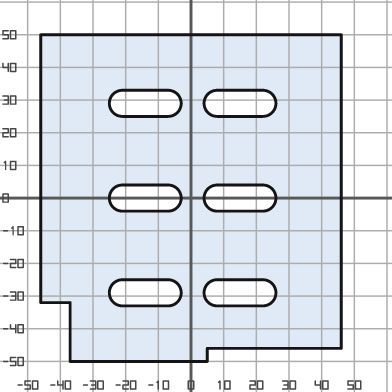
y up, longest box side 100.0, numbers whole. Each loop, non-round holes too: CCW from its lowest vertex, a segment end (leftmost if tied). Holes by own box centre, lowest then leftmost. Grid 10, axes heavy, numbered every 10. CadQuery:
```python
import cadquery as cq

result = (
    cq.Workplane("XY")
    .moveTo(-37.0, -50.0)
    .lineTo(5.0, -50.0)
    .lineTo(5.0, -46.0)
    .lineTo(46.0, -46.0)
    .lineTo(46.0, 50.0)
    .lineTo(-46.0, 50.0)
    .lineTo(-46.0, -32.0)
    .lineTo(-37.0, -32.0)
    .close()
    .moveTo(-21.0, -33.0)
    .lineTo(-7.0, -33.0)
    .threePointArc((-3.0, -29.0), (-7.0, -25.0))
    .lineTo(-21.0, -25.0)
    .threePointArc((-25.0, -29.0), (-21.0, -33.0))
    .close()
    .moveTo(8.0, -33.0)
    .lineTo(22.0, -33.0)
    .threePointArc((26.0, -29.0), (22.0, -25.0))
    .lineTo(8.0, -25.0)
    .threePointArc((4.0, -29.0), (8.0, -33.0))
    .close()
    .moveTo(-21.0, -4.0)
    .lineTo(-7.0, -4.0)
    .threePointArc((-3.0, 0.0), (-7.0, 4.0))
    .lineTo(-21.0, 4.0)
    .threePointArc((-25.0, 0.0), (-21.0, -4.0))
    .close()
    .moveTo(8.0, -4.0)
    .lineTo(22.0, -4.0)
    .threePointArc((26.0, 0.0), (22.0, 4.0))
    .lineTo(8.0, 4.0)
    .threePointArc((4.0, 0.0), (8.0, -4.0))
    .close()
    .moveTo(-21.0, 25.0)
    .lineTo(-7.0, 25.0)
    .threePointArc((-3.0, 29.0), (-7.0, 33.0))
    .lineTo(-21.0, 33.0)
    .threePointArc((-25.0, 29.0), (-21.0, 25.0))
    .close()
    .moveTo(8.0, 25.0)
    .lineTo(22.0, 25.0)
    .threePointArc((26.0, 29.0), (22.0, 33.0))
    .lineTo(8.0, 33.0)
    .threePointArc((4.0, 29.0), (8.0, 25.0))
    .close()
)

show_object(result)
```